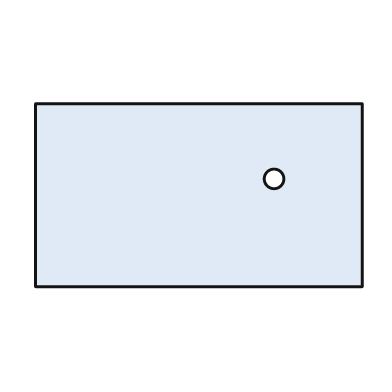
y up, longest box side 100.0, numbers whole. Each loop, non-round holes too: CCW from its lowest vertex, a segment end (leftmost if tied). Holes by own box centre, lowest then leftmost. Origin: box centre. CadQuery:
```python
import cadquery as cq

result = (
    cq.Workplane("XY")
    .moveTo(-50.0, -28.0)
    .lineTo(50.0, -28.0)
    .lineTo(50.0, 28.0)
    .lineTo(-50.0, 28.0)
    .close()
    .moveTo(23.0, 5.0)
    .circle(3.0)
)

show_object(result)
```